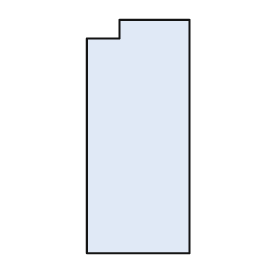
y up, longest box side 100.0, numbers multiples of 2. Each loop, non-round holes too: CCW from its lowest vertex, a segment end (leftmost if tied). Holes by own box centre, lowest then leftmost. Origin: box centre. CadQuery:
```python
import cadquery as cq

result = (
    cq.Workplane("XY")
    .moveTo(-22.0, -50.0)
    .lineTo(22.0, -50.0)
    .lineTo(22.0, 50.0)
    .lineTo(-8.0, 50.0)
    .lineTo(-8.0, 42.0)
    .lineTo(-22.0, 42.0)
    .close()
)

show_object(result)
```